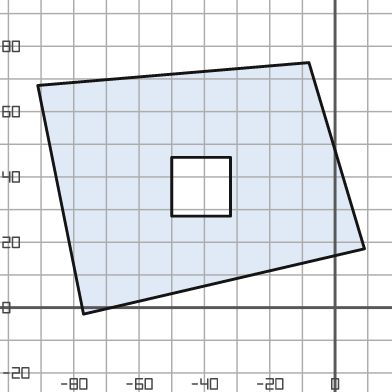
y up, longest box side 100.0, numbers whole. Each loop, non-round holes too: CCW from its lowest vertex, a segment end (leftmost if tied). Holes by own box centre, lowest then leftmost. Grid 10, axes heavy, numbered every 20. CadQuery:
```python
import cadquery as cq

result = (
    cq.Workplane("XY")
    .moveTo(-77.0, -2.0)
    .lineTo(9.0, 18.0)
    .lineTo(-8.0, 75.0)
    .lineTo(-91.0, 68.0)
    .close()
    .moveTo(-50.0, 28.0)
    .lineTo(-32.0, 28.0)
    .lineTo(-32.0, 46.0)
    .lineTo(-50.0, 46.0)
    .close()
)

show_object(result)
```